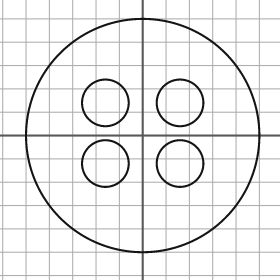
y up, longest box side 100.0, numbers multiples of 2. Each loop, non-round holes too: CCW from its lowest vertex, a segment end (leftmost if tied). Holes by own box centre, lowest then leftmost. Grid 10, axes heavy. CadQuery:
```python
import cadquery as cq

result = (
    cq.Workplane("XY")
    .moveTo(0.0, 0.0)
    .circle(50.0)
    .moveTo(-16.0, -12.0)
    .circle(10.0)
    .moveTo(16.0, -12.0)
    .circle(10.0)
    .moveTo(-16.0, 14.0)
    .circle(10.0)
    .moveTo(16.0, 14.0)
    .circle(10.0)
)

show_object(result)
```